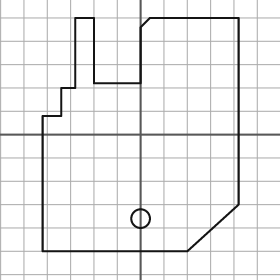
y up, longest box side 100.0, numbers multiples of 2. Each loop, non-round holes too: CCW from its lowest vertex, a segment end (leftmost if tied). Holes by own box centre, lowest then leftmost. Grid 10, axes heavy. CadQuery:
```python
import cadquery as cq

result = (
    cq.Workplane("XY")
    .moveTo(-42.0, -50.0)
    .lineTo(20.0, -50.0)
    .lineTo(42.0, -30.0)
    .lineTo(42.0, 50.0)
    .lineTo(4.0, 50.0)
    .lineTo(0.0, 46.0)
    .lineTo(0.0, 22.0)
    .lineTo(-20.0, 22.0)
    .lineTo(-20.0, 50.0)
    .lineTo(-28.0, 50.0)
    .lineTo(-28.0, 20.0)
    .lineTo(-34.0, 20.0)
    .lineTo(-34.0, 8.0)
    .lineTo(-42.0, 8.0)
    .close()
    .moveTo(0.0, -36.0)
    .circle(4.0)
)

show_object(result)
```